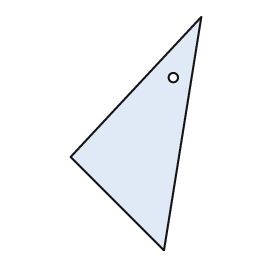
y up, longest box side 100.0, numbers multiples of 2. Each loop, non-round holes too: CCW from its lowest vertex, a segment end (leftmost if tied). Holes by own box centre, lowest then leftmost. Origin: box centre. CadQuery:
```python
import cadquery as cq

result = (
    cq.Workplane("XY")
    .moveTo(12.0, -50.0)
    .lineTo(28.0, 50.0)
    .lineTo(-28.0, -10.0)
    .close()
    .moveTo(16.0, 24.0)
    .circle(2.0)
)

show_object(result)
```